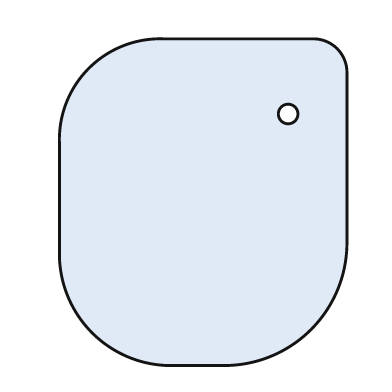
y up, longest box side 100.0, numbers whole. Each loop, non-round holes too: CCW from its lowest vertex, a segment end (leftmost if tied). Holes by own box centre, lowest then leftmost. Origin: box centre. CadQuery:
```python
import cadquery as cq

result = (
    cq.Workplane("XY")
    .moveTo(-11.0, -50.0)
    .lineTo(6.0, -50.0)
    .threePointArc((33.0, -39.0), (44.0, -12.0))
    .lineTo(44.0, 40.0)
    .threePointArc((41.0, 47.0), (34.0, 50.0))
    .lineTo(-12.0, 50.0)
    .threePointArc((-35.0, 41.0), (-44.0, 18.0))
    .lineTo(-44.0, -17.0)
    .threePointArc((-34.0, -40.0), (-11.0, -50.0))
    .close()
    .moveTo(26.0, 27.0)
    .circle(3.0)
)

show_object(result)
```